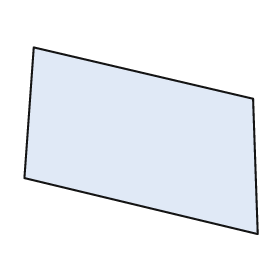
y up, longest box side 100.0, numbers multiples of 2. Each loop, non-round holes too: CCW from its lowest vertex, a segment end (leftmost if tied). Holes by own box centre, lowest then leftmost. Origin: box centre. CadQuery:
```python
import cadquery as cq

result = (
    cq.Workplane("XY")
    .moveTo(50.0, -40.0)
    .lineTo(48.0, 18.0)
    .lineTo(-46.0, 40.0)
    .lineTo(-50.0, -16.0)
    .close()
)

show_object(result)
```